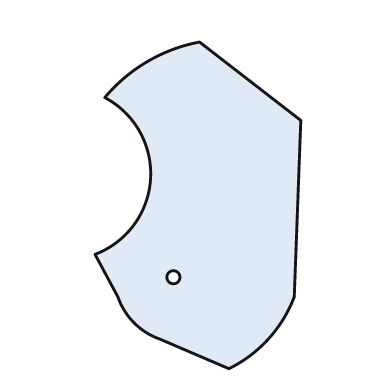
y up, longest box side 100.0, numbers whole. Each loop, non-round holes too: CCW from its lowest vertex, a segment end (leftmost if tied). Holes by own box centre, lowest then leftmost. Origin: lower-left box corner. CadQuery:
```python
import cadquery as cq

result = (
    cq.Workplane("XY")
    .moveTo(41.0, 0.0)
    .threePointArc((53.0, 9.0), (61.0, 22.0))
    .lineTo(63.0, 76.0)
    .lineTo(32.0, 100.0)
    .threePointArc((16.0, 94.0), (3.0, 83.0))
    .threePointArc((17.0, 58.0), (0.0, 35.0))
    .lineTo(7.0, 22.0)
    .threePointArc((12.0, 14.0), (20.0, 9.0))
    .close()
    .moveTo(24.0, 28.0)
    .circle(2.0)
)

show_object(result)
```